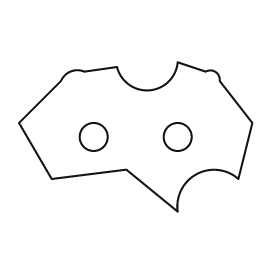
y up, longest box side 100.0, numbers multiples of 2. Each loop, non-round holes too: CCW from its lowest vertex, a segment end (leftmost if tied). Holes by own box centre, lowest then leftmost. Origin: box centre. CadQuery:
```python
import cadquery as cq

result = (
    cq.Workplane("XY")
    .moveTo(18.0, -32.0)
    .threePointArc((26.0, -16.0), (44.0, -18.0))
    .lineTo(50.0, 6.0)
    .lineTo(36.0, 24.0)
    .threePointArc((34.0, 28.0), (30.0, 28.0))
    .lineTo(18.0, 32.0)
    .threePointArc((6.0, 20.0), (-8.0, 30.0))
    .lineTo(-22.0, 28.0)
    .threePointArc((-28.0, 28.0), (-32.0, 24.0))
    .lineTo(-50.0, 6.0)
    .lineTo(-36.0, -18.0)
    .lineTo(-4.0, -14.0)
    .close()
    .moveTo(-18.0, 0.0)
    .circle(6.0)
    .moveTo(18.0, 0.0)
    .circle(6.0)
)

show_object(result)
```